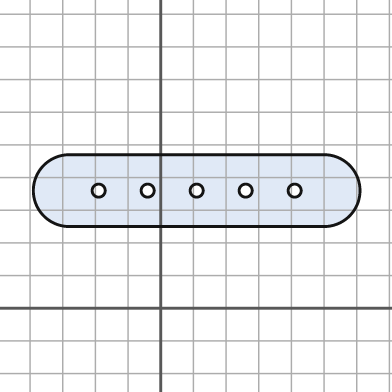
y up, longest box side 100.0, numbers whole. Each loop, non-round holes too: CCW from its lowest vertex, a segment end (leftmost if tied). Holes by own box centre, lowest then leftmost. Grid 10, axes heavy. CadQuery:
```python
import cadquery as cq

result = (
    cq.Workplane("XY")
    .moveTo(-28.0, 25.0)
    .lineTo(50.0, 25.0)
    .threePointArc((61.0, 36.0), (50.0, 47.0))
    .lineTo(-28.0, 47.0)
    .threePointArc((-39.0, 36.0), (-28.0, 25.0))
    .close()
    .moveTo(-19.0, 36.0)
    .circle(2.0)
    .moveTo(-4.0, 36.0)
    .circle(2.0)
    .moveTo(11.0, 36.0)
    .circle(2.0)
    .moveTo(26.0, 36.0)
    .circle(2.0)
    .moveTo(41.0, 36.0)
    .circle(2.0)
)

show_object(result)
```